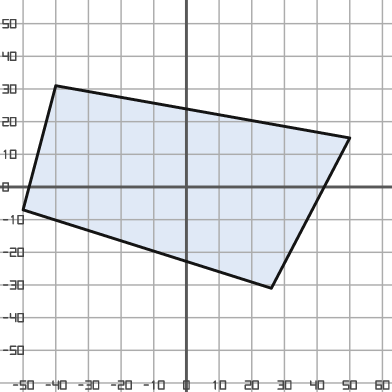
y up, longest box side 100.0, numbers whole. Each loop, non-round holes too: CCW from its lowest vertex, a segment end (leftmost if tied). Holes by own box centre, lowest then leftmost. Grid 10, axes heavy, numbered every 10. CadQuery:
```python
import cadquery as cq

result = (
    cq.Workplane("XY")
    .moveTo(26.0, -31.0)
    .lineTo(50.0, 15.0)
    .lineTo(-40.0, 31.0)
    .lineTo(-50.0, -7.0)
    .close()
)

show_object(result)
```